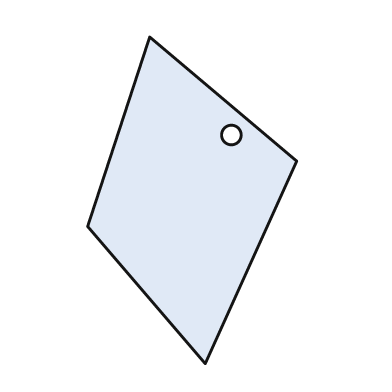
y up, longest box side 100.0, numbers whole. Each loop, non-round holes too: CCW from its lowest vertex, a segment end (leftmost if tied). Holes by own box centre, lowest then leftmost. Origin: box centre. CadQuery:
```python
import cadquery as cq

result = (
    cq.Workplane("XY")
    .moveTo(4.0, -50.0)
    .lineTo(32.0, 12.0)
    .lineTo(-13.0, 50.0)
    .lineTo(-32.0, -8.0)
    .close()
    .moveTo(12.0, 20.0)
    .circle(3.0)
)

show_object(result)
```